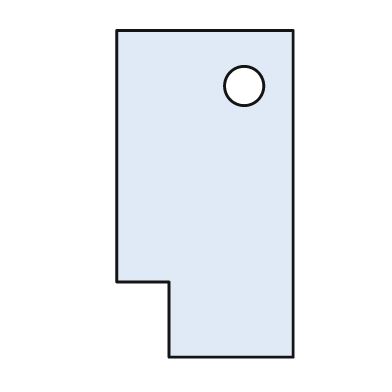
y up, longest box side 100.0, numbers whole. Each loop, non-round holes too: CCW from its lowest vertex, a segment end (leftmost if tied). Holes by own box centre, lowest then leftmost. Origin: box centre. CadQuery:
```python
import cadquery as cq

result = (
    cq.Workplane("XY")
    .moveTo(-11.0, -50.0)
    .lineTo(27.0, -50.0)
    .lineTo(27.0, 50.0)
    .lineTo(-27.0, 50.0)
    .lineTo(-27.0, -27.0)
    .lineTo(-11.0, -27.0)
    .close()
    .moveTo(12.0, 33.0)
    .circle(6.0)
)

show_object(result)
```